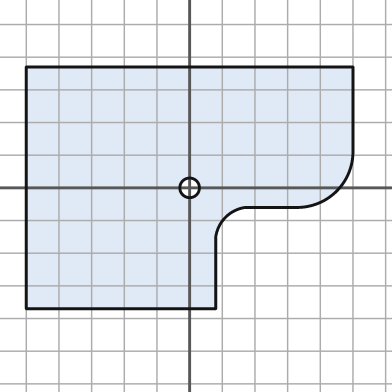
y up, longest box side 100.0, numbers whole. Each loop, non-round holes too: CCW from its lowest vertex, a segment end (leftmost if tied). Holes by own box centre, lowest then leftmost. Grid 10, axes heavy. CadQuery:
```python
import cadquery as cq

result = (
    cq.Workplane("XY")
    .moveTo(-50.0, -37.0)
    .lineTo(8.0, -37.0)
    .lineTo(8.0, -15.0)
    .threePointArc((11.0, -9.0), (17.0, -6.0))
    .lineTo(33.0, -6.0)
    .threePointArc((45.0, -1.0), (50.0, 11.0))
    .lineTo(50.0, 37.0)
    .lineTo(-50.0, 37.0)
    .close()
    .moveTo(0.0, 0.0)
    .circle(3.0)
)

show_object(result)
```